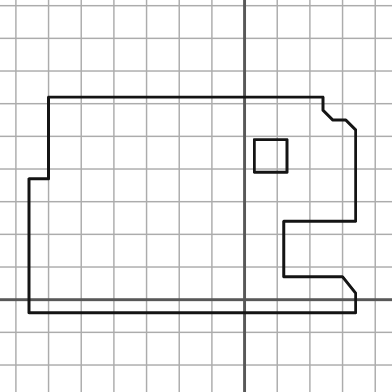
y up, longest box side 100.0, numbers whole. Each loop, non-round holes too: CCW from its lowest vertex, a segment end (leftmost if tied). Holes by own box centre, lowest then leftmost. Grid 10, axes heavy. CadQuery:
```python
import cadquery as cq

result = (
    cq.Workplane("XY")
    .moveTo(-66.0, -4.0)
    .lineTo(34.0, -4.0)
    .lineTo(34.0, 2.0)
    .lineTo(30.0, 7.0)
    .lineTo(12.0, 7.0)
    .lineTo(12.0, 24.0)
    .lineTo(34.0, 24.0)
    .lineTo(34.0, 52.0)
    .lineTo(31.0, 55.0)
    .lineTo(27.0, 55.0)
    .lineTo(24.0, 58.0)
    .lineTo(24.0, 62.0)
    .lineTo(-60.0, 62.0)
    .lineTo(-60.0, 37.0)
    .lineTo(-66.0, 37.0)
    .close()
    .moveTo(3.0, 39.0)
    .lineTo(13.0, 39.0)
    .lineTo(13.0, 49.0)
    .lineTo(3.0, 49.0)
    .close()
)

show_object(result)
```